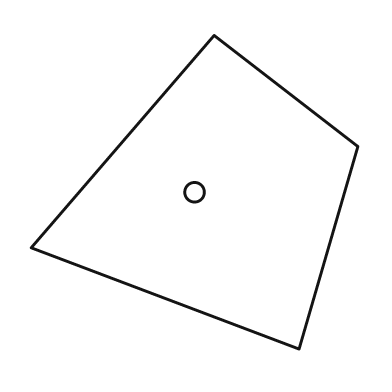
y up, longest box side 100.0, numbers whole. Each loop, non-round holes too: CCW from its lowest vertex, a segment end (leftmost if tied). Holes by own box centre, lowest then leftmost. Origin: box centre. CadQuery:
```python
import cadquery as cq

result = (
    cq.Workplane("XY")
    .moveTo(32.0, -48.0)
    .lineTo(50.0, 14.0)
    .lineTo(6.0, 48.0)
    .lineTo(-50.0, -17.0)
    .close()
    .moveTo(0.0, 0.0)
    .circle(3.0)
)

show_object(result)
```